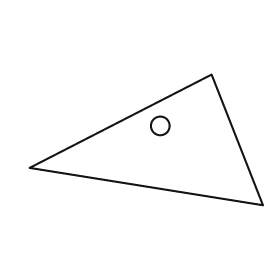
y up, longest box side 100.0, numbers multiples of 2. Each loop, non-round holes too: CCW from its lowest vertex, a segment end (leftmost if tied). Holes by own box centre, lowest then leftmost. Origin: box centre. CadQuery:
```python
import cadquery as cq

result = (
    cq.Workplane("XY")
    .moveTo(50.0, -28.0)
    .lineTo(28.0, 28.0)
    .lineTo(-50.0, -12.0)
    .close()
    .moveTo(6.0, 6.0)
    .circle(4.0)
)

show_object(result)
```